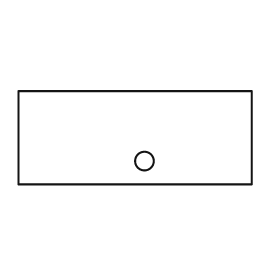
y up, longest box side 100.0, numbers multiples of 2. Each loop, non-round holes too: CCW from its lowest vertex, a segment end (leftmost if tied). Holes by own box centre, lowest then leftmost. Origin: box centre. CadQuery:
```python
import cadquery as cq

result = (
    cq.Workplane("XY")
    .moveTo(-50.0, -20.0)
    .lineTo(50.0, -20.0)
    .lineTo(50.0, 20.0)
    .lineTo(-50.0, 20.0)
    .close()
    .moveTo(4.0, -10.0)
    .circle(4.0)
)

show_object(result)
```